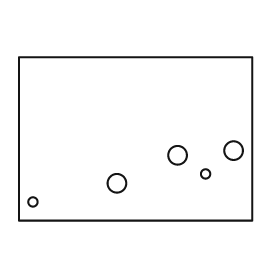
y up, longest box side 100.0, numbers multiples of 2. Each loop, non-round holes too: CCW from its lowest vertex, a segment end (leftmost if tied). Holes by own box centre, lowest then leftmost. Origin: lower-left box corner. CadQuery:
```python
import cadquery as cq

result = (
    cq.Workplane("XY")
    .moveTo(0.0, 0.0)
    .lineTo(100.0, 0.0)
    .lineTo(100.0, 70.0)
    .lineTo(0.0, 70.0)
    .close()
    .moveTo(6.0, 8.0)
    .circle(2.0)
    .moveTo(42.0, 16.0)
    .circle(4.0)
    .moveTo(80.0, 20.0)
    .circle(2.0)
    .moveTo(68.0, 28.0)
    .circle(4.0)
    .moveTo(92.0, 30.0)
    .circle(4.0)
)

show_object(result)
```